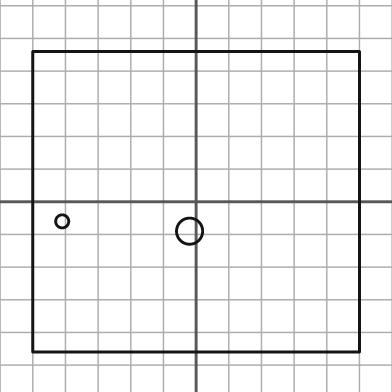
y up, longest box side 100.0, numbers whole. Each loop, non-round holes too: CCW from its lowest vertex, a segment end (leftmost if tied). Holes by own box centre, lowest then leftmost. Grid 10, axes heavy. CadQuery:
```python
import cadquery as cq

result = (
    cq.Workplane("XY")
    .moveTo(-50.0, -46.0)
    .lineTo(50.0, -46.0)
    .lineTo(50.0, 46.0)
    .lineTo(-50.0, 46.0)
    .close()
    .moveTo(-2.0, -9.0)
    .circle(4.0)
    .moveTo(-41.0, -6.0)
    .circle(2.0)
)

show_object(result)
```